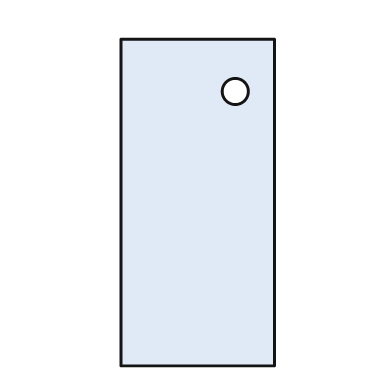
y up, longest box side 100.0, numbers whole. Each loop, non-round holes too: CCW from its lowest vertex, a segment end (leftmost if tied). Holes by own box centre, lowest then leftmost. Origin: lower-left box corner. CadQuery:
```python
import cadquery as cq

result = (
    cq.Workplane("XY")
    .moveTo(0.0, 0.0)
    .lineTo(47.0, 0.0)
    .lineTo(47.0, 100.0)
    .lineTo(0.0, 100.0)
    .close()
    .moveTo(35.0, 84.0)
    .circle(4.0)
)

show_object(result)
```